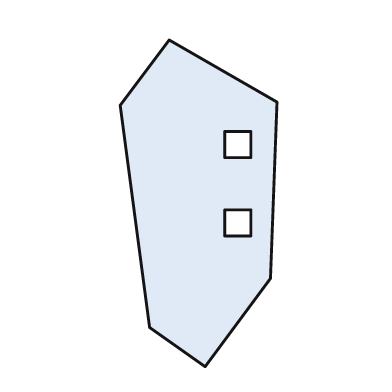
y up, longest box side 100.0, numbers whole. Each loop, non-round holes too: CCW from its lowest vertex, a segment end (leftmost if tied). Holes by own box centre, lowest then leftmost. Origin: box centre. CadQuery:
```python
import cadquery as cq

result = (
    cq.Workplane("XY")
    .moveTo(2.0, -50.0)
    .lineTo(22.0, -23.0)
    .lineTo(24.0, 31.0)
    .lineTo(-9.0, 50.0)
    .lineTo(-24.0, 30.0)
    .lineTo(-15.0, -38.0)
    .close()
    .moveTo(8.0, -10.0)
    .lineTo(16.0, -10.0)
    .lineTo(16.0, -2.0)
    .lineTo(8.0, -2.0)
    .close()
    .moveTo(8.0, 14.0)
    .lineTo(16.0, 14.0)
    .lineTo(16.0, 22.0)
    .lineTo(8.0, 22.0)
    .close()
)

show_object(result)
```